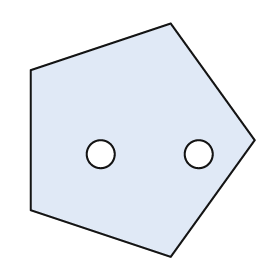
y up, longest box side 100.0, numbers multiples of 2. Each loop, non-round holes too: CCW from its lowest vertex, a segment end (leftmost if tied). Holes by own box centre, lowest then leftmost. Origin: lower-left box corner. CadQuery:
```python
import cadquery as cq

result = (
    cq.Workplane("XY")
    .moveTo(60.0, 0.0)
    .lineTo(96.0, 50.0)
    .lineTo(60.0, 100.0)
    .lineTo(0.0, 80.0)
    .lineTo(0.0, 20.0)
    .close()
    .moveTo(30.0, 44.0)
    .circle(6.0)
    .moveTo(72.0, 44.0)
    .circle(6.0)
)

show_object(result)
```